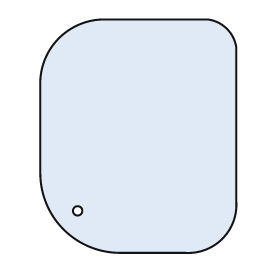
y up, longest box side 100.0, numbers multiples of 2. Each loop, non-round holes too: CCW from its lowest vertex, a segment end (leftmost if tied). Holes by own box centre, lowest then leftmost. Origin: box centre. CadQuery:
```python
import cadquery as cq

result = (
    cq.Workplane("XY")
    .moveTo(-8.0, -50.0)
    .lineTo(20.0, -50.0)
    .threePointArc((36.0, -44.0), (42.0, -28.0))
    .lineTo(42.0, 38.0)
    .threePointArc((38.0, 46.0), (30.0, 50.0))
    .lineTo(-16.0, 50.0)
    .threePointArc((-34.0, 42.0), (-42.0, 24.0))
    .lineTo(-42.0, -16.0)
    .threePointArc((-32.0, -40.0), (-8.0, -50.0))
    .close()
    .moveTo(-26.0, -32.0)
    .circle(2.0)
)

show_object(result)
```